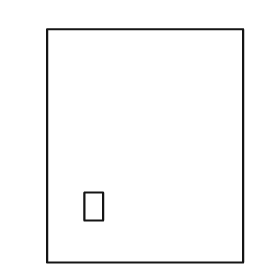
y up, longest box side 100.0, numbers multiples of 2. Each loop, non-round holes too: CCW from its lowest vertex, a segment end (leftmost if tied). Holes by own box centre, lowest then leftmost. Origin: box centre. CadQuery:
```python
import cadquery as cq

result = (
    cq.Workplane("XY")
    .moveTo(-42.0, -50.0)
    .lineTo(42.0, -50.0)
    .lineTo(42.0, 50.0)
    .lineTo(-42.0, 50.0)
    .close()
    .moveTo(-26.0, -32.0)
    .lineTo(-18.0, -32.0)
    .lineTo(-18.0, -20.0)
    .lineTo(-26.0, -20.0)
    .close()
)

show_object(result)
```